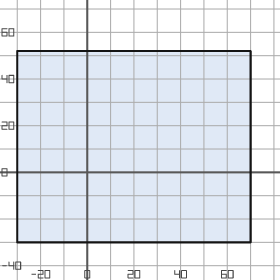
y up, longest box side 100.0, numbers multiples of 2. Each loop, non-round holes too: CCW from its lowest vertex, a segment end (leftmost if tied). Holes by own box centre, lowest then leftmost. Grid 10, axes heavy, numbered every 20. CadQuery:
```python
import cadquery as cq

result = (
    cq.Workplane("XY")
    .moveTo(-30.0, -30.0)
    .lineTo(70.0, -30.0)
    .lineTo(70.0, 52.0)
    .lineTo(-30.0, 52.0)
    .close()
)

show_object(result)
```